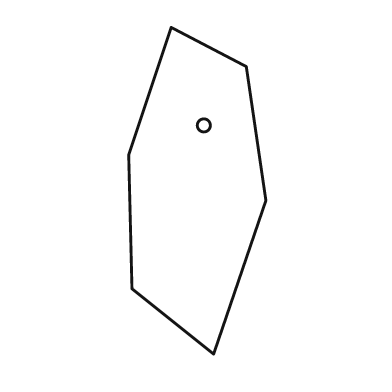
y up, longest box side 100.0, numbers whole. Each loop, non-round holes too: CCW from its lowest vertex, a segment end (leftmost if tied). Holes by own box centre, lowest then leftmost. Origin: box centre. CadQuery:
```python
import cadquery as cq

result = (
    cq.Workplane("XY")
    .moveTo(5.0, -50.0)
    .lineTo(21.0, -3.0)
    .lineTo(15.0, 38.0)
    .lineTo(-8.0, 50.0)
    .lineTo(-21.0, 11.0)
    .lineTo(-20.0, -30.0)
    .close()
    .moveTo(2.0, 20.0)
    .circle(2.0)
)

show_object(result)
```